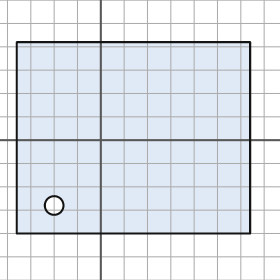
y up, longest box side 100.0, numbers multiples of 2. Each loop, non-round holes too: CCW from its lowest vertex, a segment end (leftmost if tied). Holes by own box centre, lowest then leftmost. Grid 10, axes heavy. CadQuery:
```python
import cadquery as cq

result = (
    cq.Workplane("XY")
    .moveTo(-36.0, -40.0)
    .lineTo(64.0, -40.0)
    .lineTo(64.0, 42.0)
    .lineTo(-36.0, 42.0)
    .close()
    .moveTo(-20.0, -28.0)
    .circle(4.0)
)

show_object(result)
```